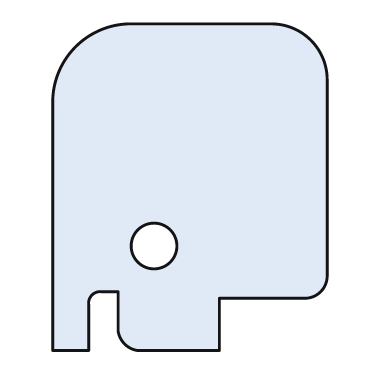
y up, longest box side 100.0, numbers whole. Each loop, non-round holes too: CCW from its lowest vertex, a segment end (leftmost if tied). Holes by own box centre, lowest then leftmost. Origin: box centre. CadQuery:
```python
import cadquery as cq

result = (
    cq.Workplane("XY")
    .moveTo(-42.0, -50.0)
    .lineTo(-31.0, -50.0)
    .lineTo(-31.0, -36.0)
    .threePointArc((-30.0, -33.0), (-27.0, -32.0))
    .lineTo(-22.0, -32.0)
    .lineTo(-22.0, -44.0)
    .threePointArc((-20.0, -48.0), (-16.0, -50.0))
    .lineTo(9.0, -50.0)
    .lineTo(9.0, -34.0)
    .lineTo(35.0, -34.0)
    .threePointArc((40.0, -32.0), (42.0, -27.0))
    .lineTo(42.0, 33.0)
    .threePointArc((37.0, 45.0), (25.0, 50.0))
    .lineTo(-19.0, 50.0)
    .threePointArc((-35.0, 43.0), (-42.0, 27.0))
    .close()
    .moveTo(-11.0, -18.0)
    .circle(7.0)
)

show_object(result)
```